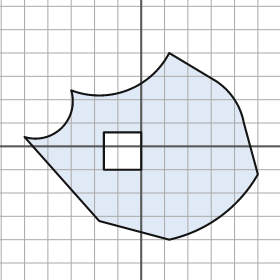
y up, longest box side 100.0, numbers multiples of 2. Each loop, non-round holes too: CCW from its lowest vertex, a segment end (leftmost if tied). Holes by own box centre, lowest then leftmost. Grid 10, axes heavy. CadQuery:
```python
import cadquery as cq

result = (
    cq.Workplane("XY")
    .moveTo(12.0, -40.0)
    .threePointArc((34.0, -30.0), (50.0, -12.0))
    .lineTo(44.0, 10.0)
    .threePointArc((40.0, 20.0), (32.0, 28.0))
    .lineTo(12.0, 40.0)
    .threePointArc((-6.0, 24.0), (-30.0, 24.0))
    .threePointArc((-34.0, 8.0), (-50.0, 4.0))
    .lineTo(-18.0, -32.0)
    .close()
    .moveTo(-16.0, -10.0)
    .lineTo(0.0, -10.0)
    .lineTo(0.0, 6.0)
    .lineTo(-16.0, 6.0)
    .close()
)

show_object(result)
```